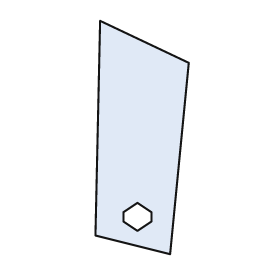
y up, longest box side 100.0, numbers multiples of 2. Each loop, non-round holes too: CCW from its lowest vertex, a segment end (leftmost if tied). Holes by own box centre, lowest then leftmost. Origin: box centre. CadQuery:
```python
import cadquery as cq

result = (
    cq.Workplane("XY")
    .moveTo(12.0, -50.0)
    .lineTo(20.0, 32.0)
    .lineTo(-18.0, 50.0)
    .lineTo(-20.0, -42.0)
    .close()
    .moveTo(-2.0, -40.0)
    .lineTo(4.0, -36.0)
    .lineTo(4.0, -32.0)
    .lineTo(-2.0, -28.0)
    .lineTo(-8.0, -32.0)
    .lineTo(-8.0, -36.0)
    .close()
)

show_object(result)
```